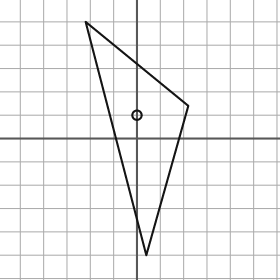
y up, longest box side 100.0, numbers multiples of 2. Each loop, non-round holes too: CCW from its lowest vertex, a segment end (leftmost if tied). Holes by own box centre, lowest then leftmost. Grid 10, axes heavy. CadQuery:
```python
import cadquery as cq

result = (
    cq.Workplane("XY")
    .moveTo(4.0, -50.0)
    .lineTo(22.0, 14.0)
    .lineTo(-22.0, 50.0)
    .close()
    .moveTo(0.0, 10.0)
    .circle(2.0)
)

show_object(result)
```